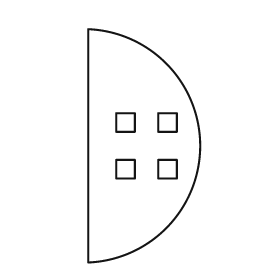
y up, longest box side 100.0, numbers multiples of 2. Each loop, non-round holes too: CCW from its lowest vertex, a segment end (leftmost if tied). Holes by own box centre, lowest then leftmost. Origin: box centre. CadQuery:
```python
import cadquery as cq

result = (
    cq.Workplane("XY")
    .moveTo(-24.0, -50.0)
    .threePointArc((24.0, 0.0), (-24.0, 50.0))
    .close()
    .moveTo(-12.0, -14.0)
    .lineTo(-4.0, -14.0)
    .lineTo(-4.0, -6.0)
    .lineTo(-12.0, -6.0)
    .close()
    .moveTo(6.0, -14.0)
    .lineTo(14.0, -14.0)
    .lineTo(14.0, -6.0)
    .lineTo(6.0, -6.0)
    .close()
    .moveTo(-12.0, 6.0)
    .lineTo(-4.0, 6.0)
    .lineTo(-4.0, 14.0)
    .lineTo(-12.0, 14.0)
    .close()
    .moveTo(6.0, 6.0)
    .lineTo(14.0, 6.0)
    .lineTo(14.0, 14.0)
    .lineTo(6.0, 14.0)
    .close()
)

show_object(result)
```